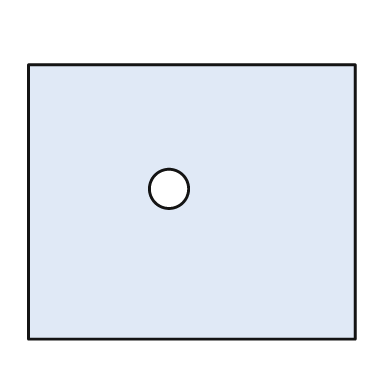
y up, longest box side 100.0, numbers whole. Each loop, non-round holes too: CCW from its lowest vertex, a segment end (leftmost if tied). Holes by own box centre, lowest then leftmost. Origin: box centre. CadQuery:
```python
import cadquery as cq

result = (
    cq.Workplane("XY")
    .moveTo(-50.0, -42.0)
    .lineTo(50.0, -42.0)
    .lineTo(50.0, 42.0)
    .lineTo(-50.0, 42.0)
    .close()
    .moveTo(-7.0, 4.0)
    .circle(6.0)
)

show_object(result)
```